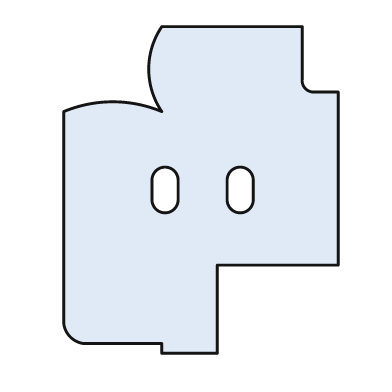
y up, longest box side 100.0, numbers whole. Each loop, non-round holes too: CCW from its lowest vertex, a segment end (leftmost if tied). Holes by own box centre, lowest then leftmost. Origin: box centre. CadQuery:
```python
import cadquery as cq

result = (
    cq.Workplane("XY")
    .moveTo(-12.0, -50.0)
    .lineTo(5.0, -50.0)
    .lineTo(5.0, -23.0)
    .lineTo(42.0, -23.0)
    .lineTo(42.0, 30.0)
    .lineTo(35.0, 30.0)
    .threePointArc((32.0, 31.0), (31.0, 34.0))
    .lineTo(31.0, 50.0)
    .lineTo(-12.0, 50.0)
    .threePointArc((-16.0, 37.0), (-12.0, 24.0))
    .threePointArc((-27.0, 27.0), (-42.0, 24.0))
    .lineTo(-42.0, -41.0)
    .threePointArc((-40.0, -45.0), (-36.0, -47.0))
    .lineTo(-12.0, -47.0)
    .close()
    .moveTo(-15.0, -3.0)
    .threePointArc((-11.0, -7.0), (-7.0, -3.0))
    .lineTo(-7.0, 3.0)
    .threePointArc((-11.0, 7.0), (-15.0, 3.0))
    .close()
    .moveTo(8.0, -3.0)
    .threePointArc((12.0, -7.0), (16.0, -3.0))
    .lineTo(16.0, 3.0)
    .threePointArc((12.0, 7.0), (8.0, 3.0))
    .close()
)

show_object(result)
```